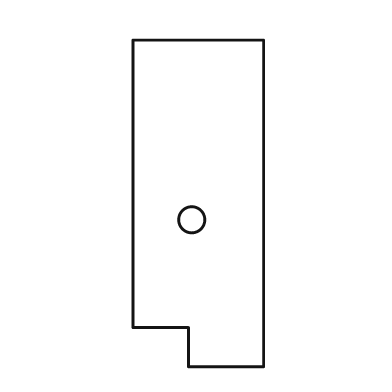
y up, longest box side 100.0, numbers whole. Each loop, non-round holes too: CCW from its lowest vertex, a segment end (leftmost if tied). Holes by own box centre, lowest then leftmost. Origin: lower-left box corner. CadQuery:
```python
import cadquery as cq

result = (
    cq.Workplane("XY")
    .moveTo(17.0, 0.0)
    .lineTo(40.0, 0.0)
    .lineTo(40.0, 100.0)
    .lineTo(0.0, 100.0)
    .lineTo(0.0, 12.0)
    .lineTo(17.0, 12.0)
    .close()
    .moveTo(18.0, 45.0)
    .circle(4.0)
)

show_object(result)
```